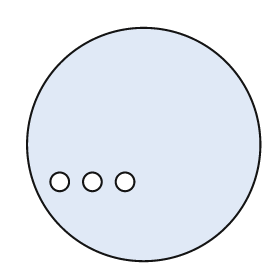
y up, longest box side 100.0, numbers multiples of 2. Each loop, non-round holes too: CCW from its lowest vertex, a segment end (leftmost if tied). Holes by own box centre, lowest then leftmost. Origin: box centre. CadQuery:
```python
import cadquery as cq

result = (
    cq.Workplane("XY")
    .moveTo(0.0, 0.0)
    .circle(50.0)
    .moveTo(-36.0, -16.0)
    .circle(4.0)
    .moveTo(-22.0, -16.0)
    .circle(4.0)
    .moveTo(-8.0, -16.0)
    .circle(4.0)
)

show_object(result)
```